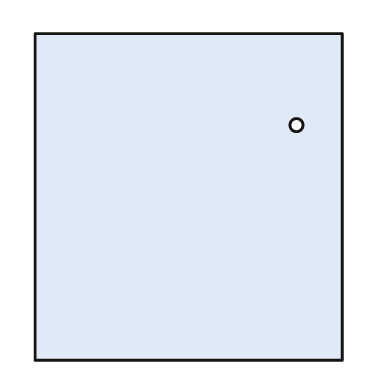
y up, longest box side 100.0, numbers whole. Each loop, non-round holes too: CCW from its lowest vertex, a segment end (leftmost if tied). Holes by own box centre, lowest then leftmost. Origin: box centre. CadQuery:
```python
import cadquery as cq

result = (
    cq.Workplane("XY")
    .moveTo(-47.0, -50.0)
    .lineTo(47.0, -50.0)
    .lineTo(47.0, 50.0)
    .lineTo(-47.0, 50.0)
    .close()
    .moveTo(33.0, 22.0)
    .circle(2.0)
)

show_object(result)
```